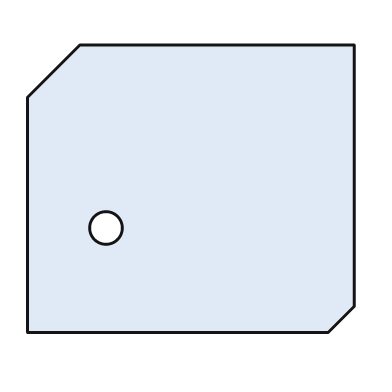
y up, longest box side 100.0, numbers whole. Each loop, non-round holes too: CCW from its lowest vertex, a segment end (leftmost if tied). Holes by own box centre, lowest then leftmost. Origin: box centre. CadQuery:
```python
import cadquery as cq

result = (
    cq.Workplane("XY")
    .moveTo(-50.0, -44.0)
    .lineTo(42.0, -44.0)
    .lineTo(50.0, -36.0)
    .lineTo(50.0, 44.0)
    .lineTo(-34.0, 44.0)
    .lineTo(-50.0, 28.0)
    .close()
    .moveTo(-26.0, -12.0)
    .circle(5.0)
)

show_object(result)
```